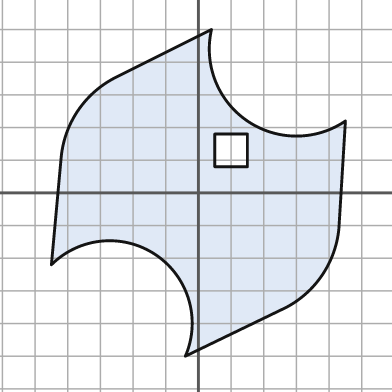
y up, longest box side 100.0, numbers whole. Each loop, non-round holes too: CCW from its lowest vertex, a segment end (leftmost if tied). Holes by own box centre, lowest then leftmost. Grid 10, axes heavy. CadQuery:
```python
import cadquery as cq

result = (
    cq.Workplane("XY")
    .moveTo(-4.0, -50.0)
    .lineTo(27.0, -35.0)
    .threePointArc((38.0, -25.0), (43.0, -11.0))
    .lineTo(45.0, 22.0)
    .threePointArc((15.0, 22.0), (4.0, 50.0))
    .lineTo(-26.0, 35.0)
    .threePointArc((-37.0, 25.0), (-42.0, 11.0))
    .lineTo(-45.0, -22.0)
    .threePointArc((-13.0, -19.0), (-4.0, -50.0))
    .close()
    .moveTo(5.0, 8.0)
    .lineTo(15.0, 8.0)
    .lineTo(15.0, 18.0)
    .lineTo(5.0, 18.0)
    .close()
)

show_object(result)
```